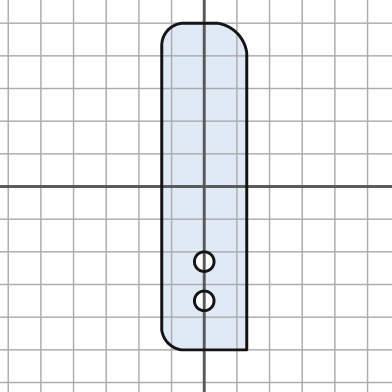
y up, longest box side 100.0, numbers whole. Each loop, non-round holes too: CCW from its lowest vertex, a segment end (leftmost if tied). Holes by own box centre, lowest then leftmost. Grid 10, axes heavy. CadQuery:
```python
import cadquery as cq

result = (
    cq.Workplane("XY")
    .moveTo(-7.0, -50.0)
    .lineTo(13.0, -50.0)
    .lineTo(13.0, 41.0)
    .threePointArc((10.0, 47.0), (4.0, 50.0))
    .lineTo(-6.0, 50.0)
    .threePointArc((-11.0, 48.0), (-13.0, 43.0))
    .lineTo(-13.0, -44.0)
    .threePointArc((-11.0, -48.0), (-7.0, -50.0))
    .close()
    .moveTo(0.0, -35.0)
    .circle(3.0)
    .moveTo(0.0, -23.0)
    .circle(3.0)
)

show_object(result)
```